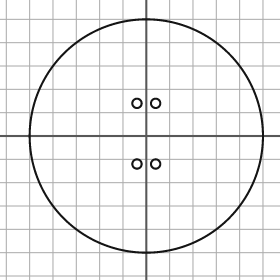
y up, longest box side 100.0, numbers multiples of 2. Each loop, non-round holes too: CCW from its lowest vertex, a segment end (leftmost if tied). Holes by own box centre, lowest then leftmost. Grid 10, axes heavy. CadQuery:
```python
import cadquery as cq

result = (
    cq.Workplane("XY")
    .moveTo(0.0, 0.0)
    .circle(50.0)
    .moveTo(-4.0, -12.0)
    .circle(2.0)
    .moveTo(4.0, -12.0)
    .circle(2.0)
    .moveTo(-4.0, 14.0)
    .circle(2.0)
    .moveTo(4.0, 14.0)
    .circle(2.0)
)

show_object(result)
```